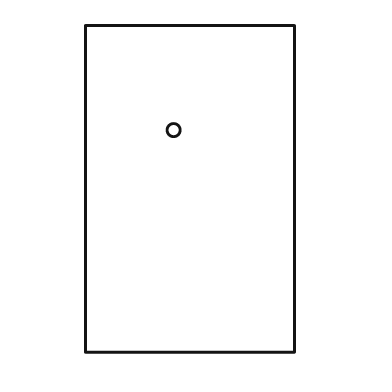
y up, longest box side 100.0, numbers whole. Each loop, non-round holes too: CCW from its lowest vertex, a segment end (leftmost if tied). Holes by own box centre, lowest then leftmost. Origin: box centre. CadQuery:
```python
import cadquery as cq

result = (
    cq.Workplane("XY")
    .moveTo(-32.0, -50.0)
    .lineTo(32.0, -50.0)
    .lineTo(32.0, 50.0)
    .lineTo(-32.0, 50.0)
    .close()
    .moveTo(-5.0, 18.0)
    .circle(2.0)
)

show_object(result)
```